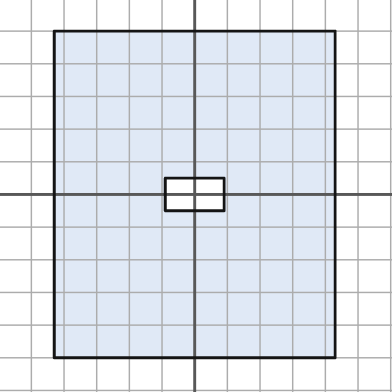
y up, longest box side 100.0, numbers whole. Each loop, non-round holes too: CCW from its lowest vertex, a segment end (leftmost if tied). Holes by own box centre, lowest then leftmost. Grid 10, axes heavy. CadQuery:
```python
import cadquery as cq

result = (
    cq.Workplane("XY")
    .moveTo(-43.0, -50.0)
    .lineTo(43.0, -50.0)
    .lineTo(43.0, 50.0)
    .lineTo(-43.0, 50.0)
    .close()
    .moveTo(-9.0, -5.0)
    .lineTo(9.0, -5.0)
    .lineTo(9.0, 5.0)
    .lineTo(-9.0, 5.0)
    .close()
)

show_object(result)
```